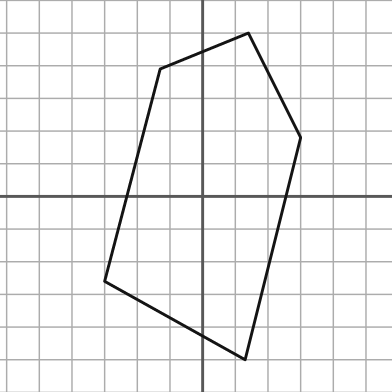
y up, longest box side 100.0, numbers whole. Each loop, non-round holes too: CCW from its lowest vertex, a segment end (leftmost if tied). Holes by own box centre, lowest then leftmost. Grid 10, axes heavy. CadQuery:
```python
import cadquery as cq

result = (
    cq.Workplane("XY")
    .moveTo(13.0, -50.0)
    .lineTo(30.0, 18.0)
    .lineTo(14.0, 50.0)
    .lineTo(-13.0, 39.0)
    .lineTo(-30.0, -26.0)
    .close()
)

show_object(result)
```